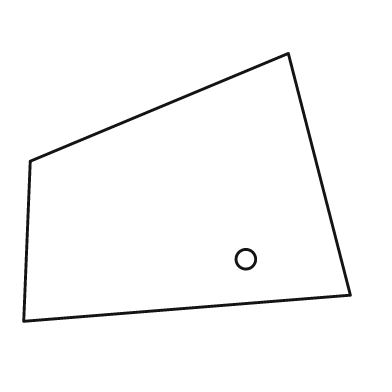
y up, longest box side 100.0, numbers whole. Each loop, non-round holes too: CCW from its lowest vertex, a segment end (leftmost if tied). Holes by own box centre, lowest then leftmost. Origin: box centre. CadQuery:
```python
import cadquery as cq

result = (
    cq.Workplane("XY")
    .moveTo(-50.0, -41.0)
    .lineTo(50.0, -33.0)
    .lineTo(31.0, 41.0)
    .lineTo(-48.0, 8.0)
    .close()
    .moveTo(18.0, -22.0)
    .circle(3.0)
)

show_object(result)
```